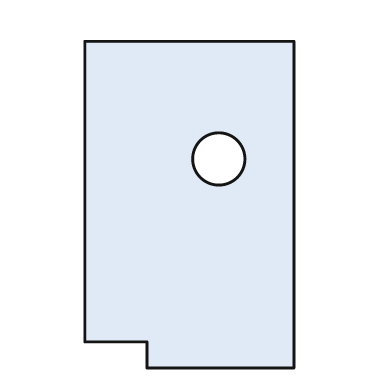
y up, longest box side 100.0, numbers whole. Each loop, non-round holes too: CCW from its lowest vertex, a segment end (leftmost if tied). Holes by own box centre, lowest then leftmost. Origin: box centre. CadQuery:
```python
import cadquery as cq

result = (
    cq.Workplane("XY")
    .moveTo(-13.0, -50.0)
    .lineTo(32.0, -50.0)
    .lineTo(32.0, 50.0)
    .lineTo(-32.0, 50.0)
    .lineTo(-32.0, -42.0)
    .lineTo(-13.0, -42.0)
    .close()
    .moveTo(9.0, 14.0)
    .circle(8.0)
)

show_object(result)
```